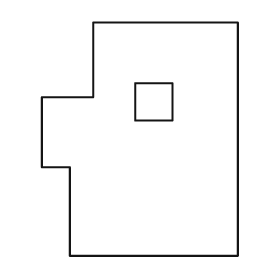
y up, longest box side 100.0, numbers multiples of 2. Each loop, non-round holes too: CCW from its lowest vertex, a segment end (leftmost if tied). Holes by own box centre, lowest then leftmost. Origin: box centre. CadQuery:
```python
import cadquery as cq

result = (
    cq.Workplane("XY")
    .moveTo(-30.0, -50.0)
    .lineTo(42.0, -50.0)
    .lineTo(42.0, 50.0)
    .lineTo(-20.0, 50.0)
    .lineTo(-20.0, 18.0)
    .lineTo(-42.0, 18.0)
    .lineTo(-42.0, -12.0)
    .lineTo(-30.0, -12.0)
    .close()
    .moveTo(-2.0, 8.0)
    .lineTo(14.0, 8.0)
    .lineTo(14.0, 24.0)
    .lineTo(-2.0, 24.0)
    .close()
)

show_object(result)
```